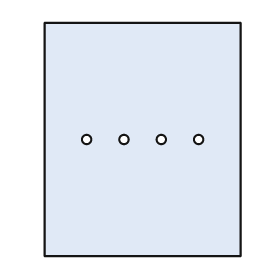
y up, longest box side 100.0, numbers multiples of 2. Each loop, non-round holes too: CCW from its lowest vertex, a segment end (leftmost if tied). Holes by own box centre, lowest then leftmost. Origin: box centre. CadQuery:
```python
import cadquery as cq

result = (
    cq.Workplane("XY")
    .moveTo(-42.0, -50.0)
    .lineTo(42.0, -50.0)
    .lineTo(42.0, 50.0)
    .lineTo(-42.0, 50.0)
    .close()
    .moveTo(-24.0, 0.0)
    .circle(2.0)
    .moveTo(-8.0, 0.0)
    .circle(2.0)
    .moveTo(8.0, 0.0)
    .circle(2.0)
    .moveTo(24.0, 0.0)
    .circle(2.0)
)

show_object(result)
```